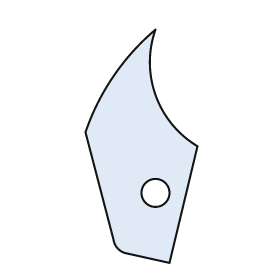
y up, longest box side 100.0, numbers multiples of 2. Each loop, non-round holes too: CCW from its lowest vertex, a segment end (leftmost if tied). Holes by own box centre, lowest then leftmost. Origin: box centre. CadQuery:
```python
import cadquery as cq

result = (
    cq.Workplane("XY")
    .moveTo(12.0, -50.0)
    .lineTo(24.0, 0.0)
    .threePointArc((6.0, 22.0), (6.0, 50.0))
    .threePointArc((-12.0, 30.0), (-24.0, 6.0))
    .lineTo(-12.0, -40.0)
    .threePointArc((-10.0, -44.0), (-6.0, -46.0))
    .close()
    .moveTo(6.0, -20.0)
    .circle(6.0)
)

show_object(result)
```